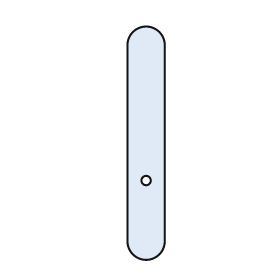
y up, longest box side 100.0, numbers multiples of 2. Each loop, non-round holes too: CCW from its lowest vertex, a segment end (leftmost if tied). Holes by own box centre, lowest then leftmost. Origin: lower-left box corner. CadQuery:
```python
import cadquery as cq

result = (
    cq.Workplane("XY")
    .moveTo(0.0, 8.0)
    .threePointArc((8.0, 0.0), (16.0, 8.0))
    .lineTo(16.0, 92.0)
    .threePointArc((8.0, 100.0), (0.0, 92.0))
    .close()
    .moveTo(8.0, 34.0)
    .circle(2.0)
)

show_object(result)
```